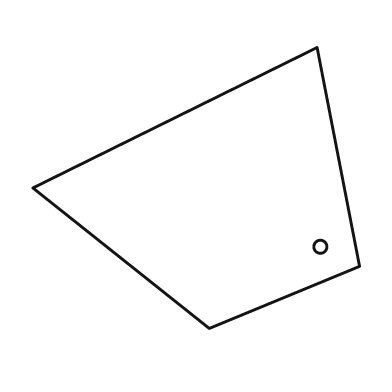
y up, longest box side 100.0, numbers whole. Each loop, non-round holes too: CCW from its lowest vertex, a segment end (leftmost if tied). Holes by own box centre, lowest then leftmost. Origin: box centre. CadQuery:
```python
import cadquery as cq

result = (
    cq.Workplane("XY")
    .moveTo(4.0, -43.0)
    .lineTo(50.0, -24.0)
    .lineTo(37.0, 43.0)
    .lineTo(-50.0, 0.0)
    .close()
    .moveTo(38.0, -18.0)
    .circle(2.0)
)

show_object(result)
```